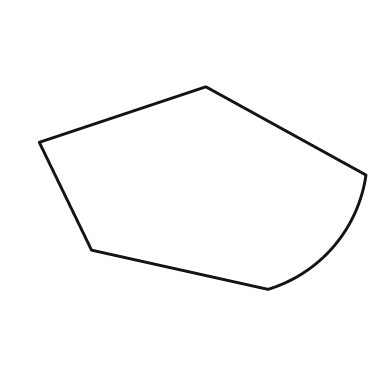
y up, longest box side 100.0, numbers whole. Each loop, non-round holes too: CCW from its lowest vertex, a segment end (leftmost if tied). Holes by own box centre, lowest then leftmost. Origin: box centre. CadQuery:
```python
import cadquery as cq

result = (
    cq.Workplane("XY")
    .moveTo(20.0, -31.0)
    .threePointArc((40.0, -18.0), (50.0, 4.0))
    .lineTo(1.0, 31.0)
    .lineTo(-50.0, 14.0)
    .lineTo(-34.0, -19.0)
    .close()
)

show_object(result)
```